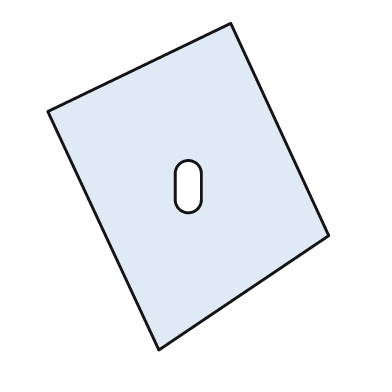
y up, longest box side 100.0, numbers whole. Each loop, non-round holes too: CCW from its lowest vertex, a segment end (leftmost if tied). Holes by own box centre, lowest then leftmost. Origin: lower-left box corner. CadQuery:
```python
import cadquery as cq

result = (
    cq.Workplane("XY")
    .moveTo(34.0, 0.0)
    .lineTo(86.0, 35.0)
    .lineTo(56.0, 100.0)
    .lineTo(0.0, 73.0)
    .close()
    .moveTo(39.0, 46.0)
    .threePointArc((43.0, 42.0), (47.0, 46.0))
    .lineTo(47.0, 54.0)
    .threePointArc((43.0, 58.0), (39.0, 54.0))
    .close()
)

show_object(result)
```